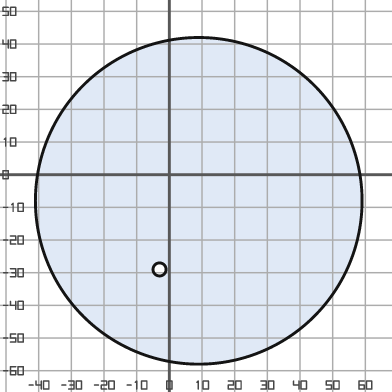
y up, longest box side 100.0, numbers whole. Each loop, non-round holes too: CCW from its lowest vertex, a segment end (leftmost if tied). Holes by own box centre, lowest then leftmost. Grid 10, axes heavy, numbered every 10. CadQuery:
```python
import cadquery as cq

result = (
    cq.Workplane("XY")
    .moveTo(9.0, -8.0)
    .circle(50.0)
    .moveTo(-3.0, -29.0)
    .circle(2.0)
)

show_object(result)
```